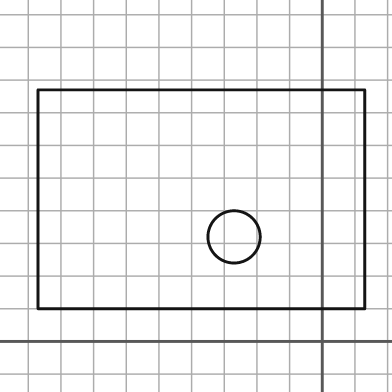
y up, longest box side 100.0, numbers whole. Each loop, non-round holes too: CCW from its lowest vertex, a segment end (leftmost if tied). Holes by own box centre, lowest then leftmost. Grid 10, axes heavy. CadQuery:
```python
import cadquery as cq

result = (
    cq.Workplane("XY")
    .moveTo(-87.0, 10.0)
    .lineTo(13.0, 10.0)
    .lineTo(13.0, 77.0)
    .lineTo(-87.0, 77.0)
    .close()
    .moveTo(-27.0, 32.0)
    .circle(8.0)
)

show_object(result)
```